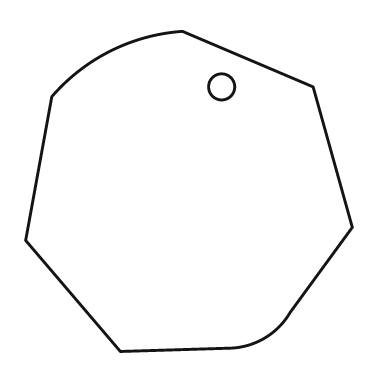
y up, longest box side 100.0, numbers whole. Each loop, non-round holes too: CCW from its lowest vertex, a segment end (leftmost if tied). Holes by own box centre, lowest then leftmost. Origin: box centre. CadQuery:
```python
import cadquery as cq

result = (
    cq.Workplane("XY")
    .moveTo(-21.0, -49.0)
    .lineTo(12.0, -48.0)
    .threePointArc((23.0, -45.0), (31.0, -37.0))
    .lineTo(50.0, -11.0)
    .lineTo(38.0, 32.0)
    .lineTo(-2.0, 49.0)
    .threePointArc((-24.0, 43.0), (-42.0, 29.0))
    .lineTo(-50.0, -15.0)
    .close()
    .moveTo(10.0, 32.0)
    .circle(4.0)
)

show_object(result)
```